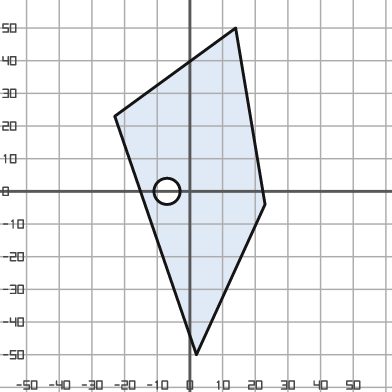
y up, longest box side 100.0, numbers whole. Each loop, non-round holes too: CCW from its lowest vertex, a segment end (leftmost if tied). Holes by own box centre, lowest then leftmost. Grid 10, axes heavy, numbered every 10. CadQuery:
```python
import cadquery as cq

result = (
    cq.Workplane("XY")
    .moveTo(2.0, -50.0)
    .lineTo(23.0, -4.0)
    .lineTo(14.0, 50.0)
    .lineTo(-23.0, 23.0)
    .close()
    .moveTo(-7.0, 0.0)
    .circle(4.0)
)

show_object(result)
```